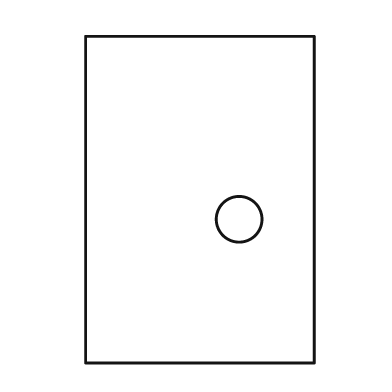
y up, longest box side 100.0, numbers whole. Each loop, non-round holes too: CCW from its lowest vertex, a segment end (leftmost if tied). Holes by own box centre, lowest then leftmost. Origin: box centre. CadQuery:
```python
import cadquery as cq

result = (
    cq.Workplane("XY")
    .moveTo(-35.0, -50.0)
    .lineTo(35.0, -50.0)
    .lineTo(35.0, 50.0)
    .lineTo(-35.0, 50.0)
    .close()
    .moveTo(12.0, -6.0)
    .circle(7.0)
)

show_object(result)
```